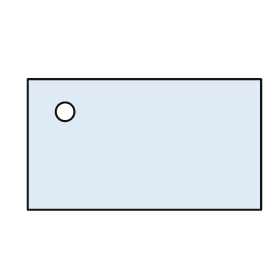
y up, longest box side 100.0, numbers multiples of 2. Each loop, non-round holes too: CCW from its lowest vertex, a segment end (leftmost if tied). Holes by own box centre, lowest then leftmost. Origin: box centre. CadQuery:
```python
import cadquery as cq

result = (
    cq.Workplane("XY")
    .moveTo(-50.0, -28.0)
    .lineTo(50.0, -28.0)
    .lineTo(50.0, 28.0)
    .lineTo(-50.0, 28.0)
    .close()
    .moveTo(-34.0, 14.0)
    .circle(4.0)
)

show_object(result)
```